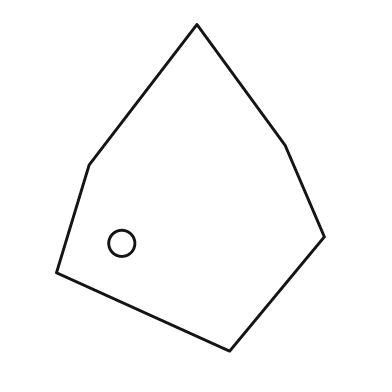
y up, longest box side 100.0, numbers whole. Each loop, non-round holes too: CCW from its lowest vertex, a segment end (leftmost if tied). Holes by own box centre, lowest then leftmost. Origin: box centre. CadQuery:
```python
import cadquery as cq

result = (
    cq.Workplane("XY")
    .moveTo(12.0, -50.0)
    .lineTo(41.0, -15.0)
    .lineTo(29.0, 13.0)
    .lineTo(2.0, 50.0)
    .lineTo(-31.0, 7.0)
    .lineTo(-41.0, -26.0)
    .close()
    .moveTo(-21.0, -17.0)
    .circle(4.0)
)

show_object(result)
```